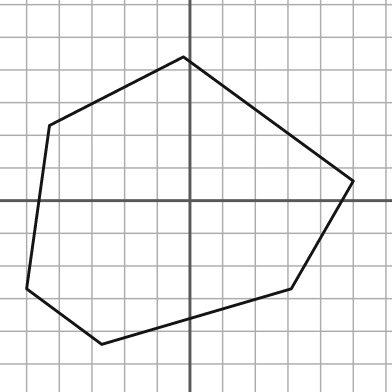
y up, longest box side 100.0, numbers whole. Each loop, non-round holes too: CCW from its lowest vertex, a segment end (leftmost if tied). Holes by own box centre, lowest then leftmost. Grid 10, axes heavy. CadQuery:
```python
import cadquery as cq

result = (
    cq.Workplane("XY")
    .moveTo(-27.0, -44.0)
    .lineTo(31.0, -27.0)
    .lineTo(50.0, 6.0)
    .lineTo(-2.0, 44.0)
    .lineTo(-43.0, 23.0)
    .lineTo(-50.0, -27.0)
    .close()
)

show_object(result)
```